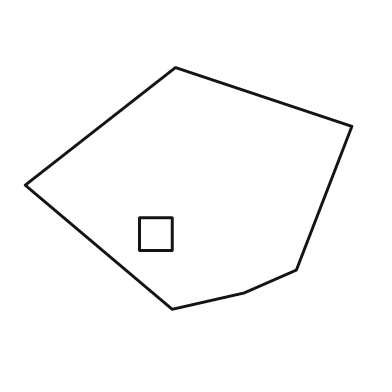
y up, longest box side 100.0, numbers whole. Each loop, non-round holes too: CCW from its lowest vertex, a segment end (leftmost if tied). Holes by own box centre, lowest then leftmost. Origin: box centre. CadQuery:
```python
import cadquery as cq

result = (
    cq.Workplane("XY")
    .moveTo(-5.0, -37.0)
    .lineTo(17.0, -32.0)
    .lineTo(33.0, -25.0)
    .lineTo(50.0, 19.0)
    .lineTo(-4.0, 37.0)
    .lineTo(-50.0, 1.0)
    .close()
    .moveTo(-15.0, -19.0)
    .lineTo(-5.0, -19.0)
    .lineTo(-5.0, -9.0)
    .lineTo(-15.0, -9.0)
    .close()
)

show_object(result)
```